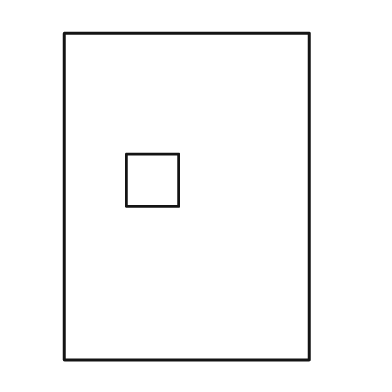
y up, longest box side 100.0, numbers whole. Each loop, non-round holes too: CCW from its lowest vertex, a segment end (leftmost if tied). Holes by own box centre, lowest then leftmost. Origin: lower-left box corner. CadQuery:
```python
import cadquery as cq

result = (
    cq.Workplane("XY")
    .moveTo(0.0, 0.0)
    .lineTo(75.0, 0.0)
    .lineTo(75.0, 100.0)
    .lineTo(0.0, 100.0)
    .close()
    .moveTo(19.0, 47.0)
    .lineTo(35.0, 47.0)
    .lineTo(35.0, 63.0)
    .lineTo(19.0, 63.0)
    .close()
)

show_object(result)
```